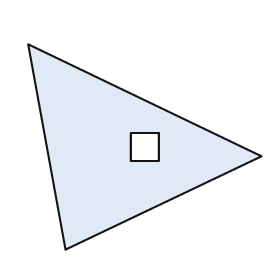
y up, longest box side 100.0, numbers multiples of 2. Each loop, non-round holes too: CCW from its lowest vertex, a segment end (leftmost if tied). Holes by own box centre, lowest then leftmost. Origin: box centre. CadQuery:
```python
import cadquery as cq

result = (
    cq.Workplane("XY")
    .moveTo(-34.0, -44.0)
    .lineTo(50.0, -4.0)
    .lineTo(-50.0, 44.0)
    .close()
    .moveTo(-6.0, -6.0)
    .lineTo(6.0, -6.0)
    .lineTo(6.0, 6.0)
    .lineTo(-6.0, 6.0)
    .close()
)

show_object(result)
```